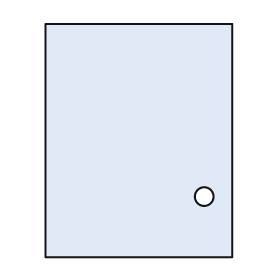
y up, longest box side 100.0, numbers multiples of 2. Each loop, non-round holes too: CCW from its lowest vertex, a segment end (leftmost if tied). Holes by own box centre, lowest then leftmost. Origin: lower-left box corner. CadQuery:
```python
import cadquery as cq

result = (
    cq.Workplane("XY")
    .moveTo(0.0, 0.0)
    .lineTo(80.0, 0.0)
    .lineTo(80.0, 100.0)
    .lineTo(0.0, 100.0)
    .close()
    .moveTo(68.0, 26.0)
    .circle(4.0)
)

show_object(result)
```